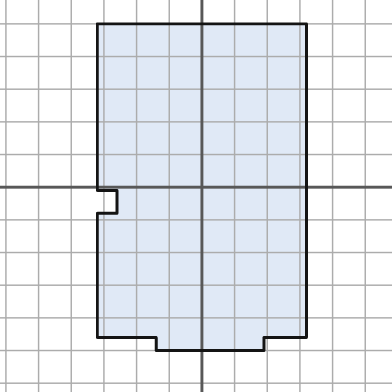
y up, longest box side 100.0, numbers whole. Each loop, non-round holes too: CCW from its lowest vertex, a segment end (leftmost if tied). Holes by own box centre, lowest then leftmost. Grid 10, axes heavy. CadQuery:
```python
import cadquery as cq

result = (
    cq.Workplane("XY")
    .moveTo(-14.0, -50.0)
    .lineTo(19.0, -50.0)
    .lineTo(19.0, -46.0)
    .lineTo(32.0, -46.0)
    .lineTo(32.0, 50.0)
    .lineTo(-32.0, 50.0)
    .lineTo(-32.0, -1.0)
    .lineTo(-26.0, -1.0)
    .lineTo(-26.0, -8.0)
    .lineTo(-32.0, -8.0)
    .lineTo(-32.0, -46.0)
    .lineTo(-14.0, -46.0)
    .close()
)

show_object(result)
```